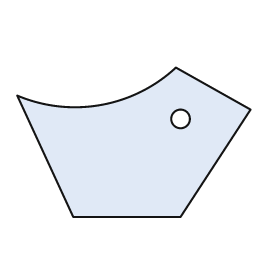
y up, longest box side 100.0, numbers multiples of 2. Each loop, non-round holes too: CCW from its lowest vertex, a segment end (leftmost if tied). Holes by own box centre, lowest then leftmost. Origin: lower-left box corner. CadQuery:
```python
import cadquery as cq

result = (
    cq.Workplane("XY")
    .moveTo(24.0, 0.0)
    .lineTo(70.0, 0.0)
    .lineTo(100.0, 46.0)
    .lineTo(68.0, 64.0)
    .threePointArc((36.0, 48.0), (0.0, 52.0))
    .close()
    .moveTo(70.0, 42.0)
    .circle(4.0)
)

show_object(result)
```